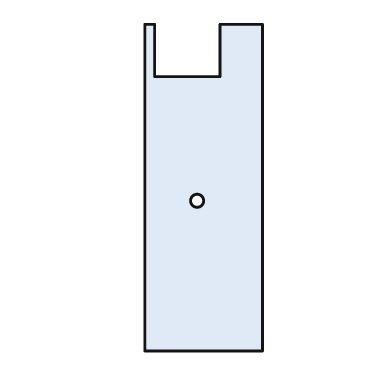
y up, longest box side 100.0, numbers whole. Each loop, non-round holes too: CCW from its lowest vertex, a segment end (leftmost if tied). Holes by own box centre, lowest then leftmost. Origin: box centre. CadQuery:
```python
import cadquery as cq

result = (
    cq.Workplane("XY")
    .moveTo(-18.0, -50.0)
    .lineTo(18.0, -50.0)
    .lineTo(18.0, 50.0)
    .lineTo(5.0, 50.0)
    .lineTo(5.0, 34.0)
    .lineTo(-15.0, 34.0)
    .lineTo(-15.0, 50.0)
    .lineTo(-18.0, 50.0)
    .close()
    .moveTo(-2.0, -4.0)
    .circle(2.0)
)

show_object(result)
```